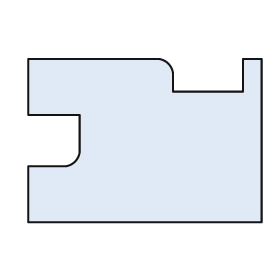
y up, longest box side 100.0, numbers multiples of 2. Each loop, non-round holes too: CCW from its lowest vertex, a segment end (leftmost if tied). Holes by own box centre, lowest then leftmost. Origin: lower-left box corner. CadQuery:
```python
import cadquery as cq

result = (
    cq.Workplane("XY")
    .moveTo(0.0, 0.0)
    .lineTo(100.0, 0.0)
    .lineTo(100.0, 70.0)
    .lineTo(92.0, 70.0)
    .lineTo(92.0, 56.0)
    .lineTo(62.0, 56.0)
    .lineTo(62.0, 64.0)
    .threePointArc((60.0, 68.0), (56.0, 70.0))
    .lineTo(0.0, 70.0)
    .lineTo(0.0, 46.0)
    .lineTo(22.0, 46.0)
    .lineTo(22.0, 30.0)
    .threePointArc((20.0, 26.0), (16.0, 24.0))
    .lineTo(0.0, 24.0)
    .close()
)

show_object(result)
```